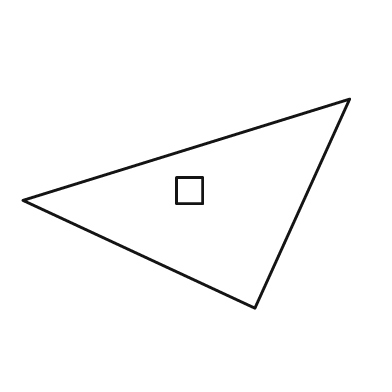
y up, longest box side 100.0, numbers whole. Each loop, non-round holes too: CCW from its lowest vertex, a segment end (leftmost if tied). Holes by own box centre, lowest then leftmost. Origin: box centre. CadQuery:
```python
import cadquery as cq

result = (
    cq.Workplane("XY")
    .moveTo(21.0, -32.0)
    .lineTo(50.0, 32.0)
    .lineTo(-50.0, 1.0)
    .close()
    .moveTo(-3.0, 0.0)
    .lineTo(5.0, 0.0)
    .lineTo(5.0, 8.0)
    .lineTo(-3.0, 8.0)
    .close()
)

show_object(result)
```